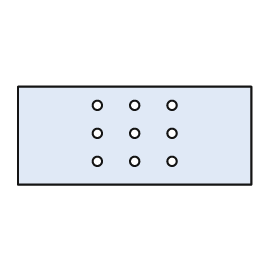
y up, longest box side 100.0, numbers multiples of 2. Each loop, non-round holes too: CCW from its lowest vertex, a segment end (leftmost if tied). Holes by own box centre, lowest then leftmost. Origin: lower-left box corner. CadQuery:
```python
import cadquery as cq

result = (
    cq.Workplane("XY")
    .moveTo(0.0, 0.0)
    .lineTo(100.0, 0.0)
    .lineTo(100.0, 42.0)
    .lineTo(0.0, 42.0)
    .close()
    .moveTo(34.0, 10.0)
    .circle(2.0)
    .moveTo(50.0, 10.0)
    .circle(2.0)
    .moveTo(66.0, 10.0)
    .circle(2.0)
    .moveTo(34.0, 22.0)
    .circle(2.0)
    .moveTo(50.0, 22.0)
    .circle(2.0)
    .moveTo(66.0, 22.0)
    .circle(2.0)
    .moveTo(34.0, 34.0)
    .circle(2.0)
    .moveTo(50.0, 34.0)
    .circle(2.0)
    .moveTo(66.0, 34.0)
    .circle(2.0)
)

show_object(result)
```